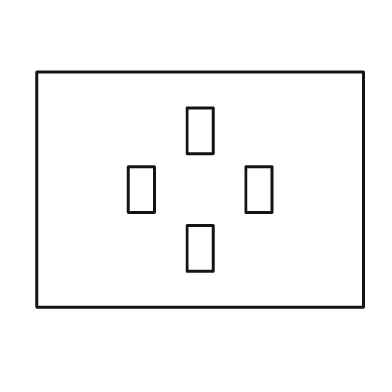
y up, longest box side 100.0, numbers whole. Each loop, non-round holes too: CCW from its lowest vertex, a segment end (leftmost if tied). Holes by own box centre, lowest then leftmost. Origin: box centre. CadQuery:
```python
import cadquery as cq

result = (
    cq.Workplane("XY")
    .moveTo(-50.0, -36.0)
    .lineTo(50.0, -36.0)
    .lineTo(50.0, 36.0)
    .lineTo(-50.0, 36.0)
    .close()
    .moveTo(-4.0, -25.0)
    .lineTo(4.0, -25.0)
    .lineTo(4.0, -11.0)
    .lineTo(-4.0, -11.0)
    .close()
    .moveTo(-22.0, -7.0)
    .lineTo(-14.0, -7.0)
    .lineTo(-14.0, 7.0)
    .lineTo(-22.0, 7.0)
    .close()
    .moveTo(14.0, -7.0)
    .lineTo(22.0, -7.0)
    .lineTo(22.0, 7.0)
    .lineTo(14.0, 7.0)
    .close()
    .moveTo(-4.0, 11.0)
    .lineTo(4.0, 11.0)
    .lineTo(4.0, 25.0)
    .lineTo(-4.0, 25.0)
    .close()
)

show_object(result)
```